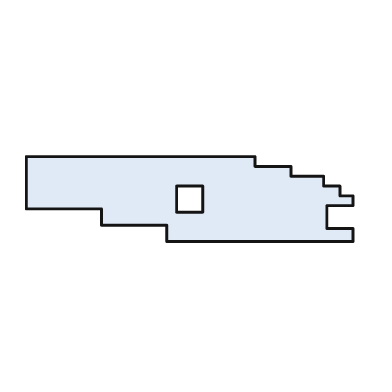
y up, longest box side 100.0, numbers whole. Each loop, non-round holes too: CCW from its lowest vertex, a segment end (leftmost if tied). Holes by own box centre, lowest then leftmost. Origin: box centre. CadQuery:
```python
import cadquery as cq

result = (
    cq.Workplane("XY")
    .moveTo(-7.0, -13.0)
    .lineTo(50.0, -13.0)
    .lineTo(50.0, -9.0)
    .lineTo(42.0, -9.0)
    .lineTo(42.0, -2.0)
    .lineTo(50.0, -2.0)
    .lineTo(50.0, 1.0)
    .lineTo(46.0, 1.0)
    .lineTo(46.0, 4.0)
    .lineTo(41.0, 4.0)
    .lineTo(41.0, 7.0)
    .lineTo(31.0, 7.0)
    .lineTo(31.0, 10.0)
    .lineTo(20.0, 10.0)
    .lineTo(20.0, 13.0)
    .lineTo(-50.0, 13.0)
    .lineTo(-50.0, -3.0)
    .lineTo(-27.0, -3.0)
    .lineTo(-27.0, -8.0)
    .lineTo(-7.0, -8.0)
    .close()
    .moveTo(-4.0, -4.0)
    .lineTo(4.0, -4.0)
    .lineTo(4.0, 4.0)
    .lineTo(-4.0, 4.0)
    .close()
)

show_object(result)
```